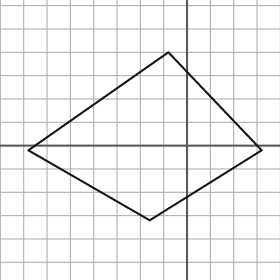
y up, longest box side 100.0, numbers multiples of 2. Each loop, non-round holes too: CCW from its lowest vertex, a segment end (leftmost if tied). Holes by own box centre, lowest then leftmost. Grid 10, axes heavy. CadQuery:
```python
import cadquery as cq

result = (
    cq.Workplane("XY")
    .moveTo(-16.0, -32.0)
    .lineTo(32.0, -2.0)
    .lineTo(-8.0, 40.0)
    .lineTo(-68.0, -2.0)
    .close()
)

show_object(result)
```